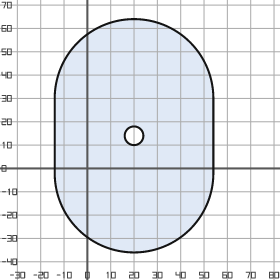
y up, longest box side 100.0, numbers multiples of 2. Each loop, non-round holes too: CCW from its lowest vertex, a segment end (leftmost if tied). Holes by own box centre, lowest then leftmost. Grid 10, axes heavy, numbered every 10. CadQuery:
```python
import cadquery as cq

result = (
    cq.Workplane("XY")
    .moveTo(-14.0, -2.0)
    .threePointArc((20.0, -36.0), (54.0, -2.0))
    .lineTo(54.0, 30.0)
    .threePointArc((20.0, 64.0), (-14.0, 30.0))
    .close()
    .moveTo(20.0, 14.0)
    .circle(4.0)
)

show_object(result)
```